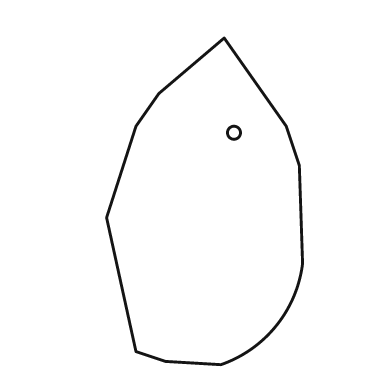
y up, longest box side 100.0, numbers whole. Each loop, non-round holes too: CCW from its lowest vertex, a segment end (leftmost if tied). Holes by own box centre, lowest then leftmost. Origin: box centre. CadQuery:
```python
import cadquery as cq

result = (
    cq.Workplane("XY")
    .moveTo(5.0, -50.0)
    .threePointArc((22.0, -38.0), (30.0, -19.0))
    .lineTo(29.0, 11.0)
    .lineTo(25.0, 23.0)
    .lineTo(6.0, 50.0)
    .lineTo(-14.0, 33.0)
    .lineTo(-21.0, 23.0)
    .lineTo(-30.0, -5.0)
    .lineTo(-21.0, -46.0)
    .lineTo(-12.0, -49.0)
    .close()
    .moveTo(9.0, 21.0)
    .circle(2.0)
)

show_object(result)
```